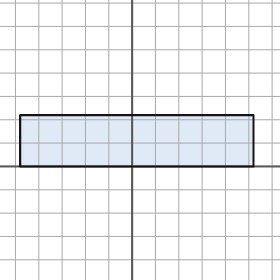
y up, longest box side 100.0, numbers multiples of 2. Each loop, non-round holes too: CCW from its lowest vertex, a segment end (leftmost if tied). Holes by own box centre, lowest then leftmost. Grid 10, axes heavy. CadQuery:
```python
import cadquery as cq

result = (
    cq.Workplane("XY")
    .moveTo(-48.0, 0.0)
    .lineTo(52.0, 0.0)
    .lineTo(52.0, 22.0)
    .lineTo(-48.0, 22.0)
    .close()
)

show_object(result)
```